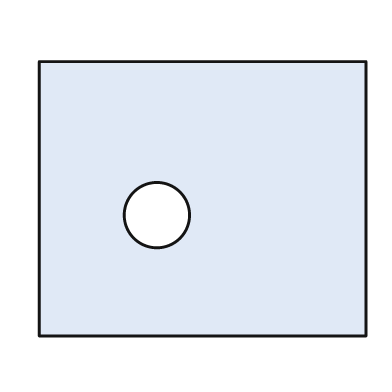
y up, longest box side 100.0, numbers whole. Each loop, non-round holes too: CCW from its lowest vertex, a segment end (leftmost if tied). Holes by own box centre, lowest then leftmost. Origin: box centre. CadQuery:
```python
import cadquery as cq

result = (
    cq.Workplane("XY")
    .moveTo(-50.0, -42.0)
    .lineTo(50.0, -42.0)
    .lineTo(50.0, 42.0)
    .lineTo(-50.0, 42.0)
    .close()
    .moveTo(-14.0, -5.0)
    .circle(10.0)
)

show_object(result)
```